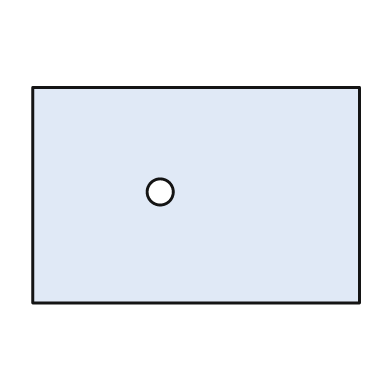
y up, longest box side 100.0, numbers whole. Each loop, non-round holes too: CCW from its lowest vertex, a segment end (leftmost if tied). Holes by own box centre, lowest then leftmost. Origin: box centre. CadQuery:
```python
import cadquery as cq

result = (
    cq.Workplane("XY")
    .moveTo(-50.0, -33.0)
    .lineTo(50.0, -33.0)
    .lineTo(50.0, 33.0)
    .lineTo(-50.0, 33.0)
    .close()
    .moveTo(-11.0, 1.0)
    .circle(4.0)
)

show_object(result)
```